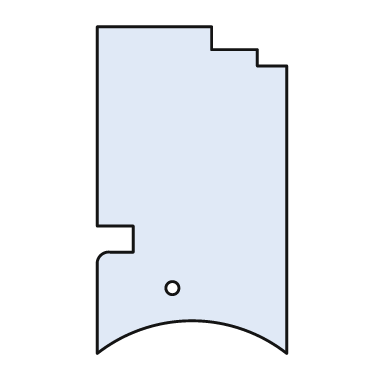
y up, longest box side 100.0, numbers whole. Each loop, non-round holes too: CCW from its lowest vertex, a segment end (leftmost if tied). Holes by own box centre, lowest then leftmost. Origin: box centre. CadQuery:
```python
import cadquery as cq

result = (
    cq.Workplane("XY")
    .moveTo(-29.0, -50.0)
    .threePointArc((0.0, -40.0), (29.0, -50.0))
    .lineTo(29.0, 38.0)
    .lineTo(20.0, 38.0)
    .lineTo(20.0, 43.0)
    .lineTo(6.0, 43.0)
    .lineTo(6.0, 50.0)
    .lineTo(-29.0, 50.0)
    .lineTo(-29.0, -11.0)
    .lineTo(-18.0, -11.0)
    .lineTo(-18.0, -19.0)
    .lineTo(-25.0, -19.0)
    .threePointArc((-28.0, -20.0), (-29.0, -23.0))
    .close()
    .moveTo(-6.0, -30.0)
    .circle(2.0)
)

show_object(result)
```